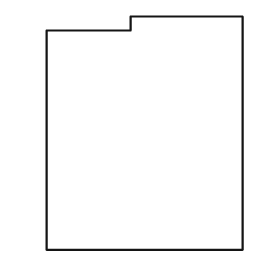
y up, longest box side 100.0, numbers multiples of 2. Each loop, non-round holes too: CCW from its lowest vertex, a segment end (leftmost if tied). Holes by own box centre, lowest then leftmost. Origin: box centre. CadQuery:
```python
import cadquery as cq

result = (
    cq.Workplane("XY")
    .moveTo(-42.0, -50.0)
    .lineTo(42.0, -50.0)
    .lineTo(42.0, 50.0)
    .lineTo(-6.0, 50.0)
    .lineTo(-6.0, 44.0)
    .lineTo(-42.0, 44.0)
    .close()
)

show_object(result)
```